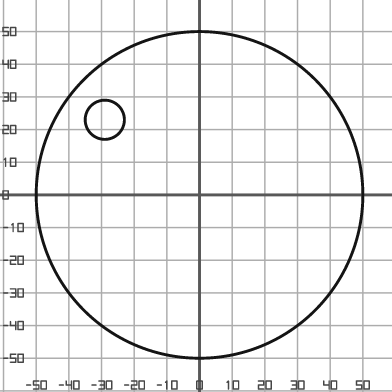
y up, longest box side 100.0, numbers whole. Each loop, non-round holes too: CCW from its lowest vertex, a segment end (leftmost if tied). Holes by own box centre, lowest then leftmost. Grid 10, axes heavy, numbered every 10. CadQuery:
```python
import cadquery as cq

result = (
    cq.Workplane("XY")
    .moveTo(0.0, 0.0)
    .circle(50.0)
    .moveTo(-29.0, 23.0)
    .circle(6.0)
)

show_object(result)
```